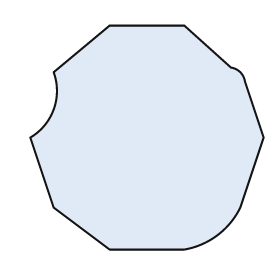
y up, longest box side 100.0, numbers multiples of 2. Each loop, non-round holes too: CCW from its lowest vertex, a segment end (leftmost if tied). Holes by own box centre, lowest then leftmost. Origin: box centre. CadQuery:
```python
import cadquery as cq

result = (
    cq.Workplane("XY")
    .moveTo(-16.0, -48.0)
    .lineTo(16.0, -48.0)
    .threePointArc((30.0, -42.0), (40.0, -30.0))
    .lineTo(50.0, 0.0)
    .lineTo(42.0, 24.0)
    .threePointArc((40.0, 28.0), (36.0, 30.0))
    .lineTo(16.0, 48.0)
    .lineTo(-16.0, 48.0)
    .lineTo(-40.0, 28.0)
    .threePointArc((-40.0, 12.0), (-50.0, 0.0))
    .lineTo(-40.0, -30.0)
    .close()
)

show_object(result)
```